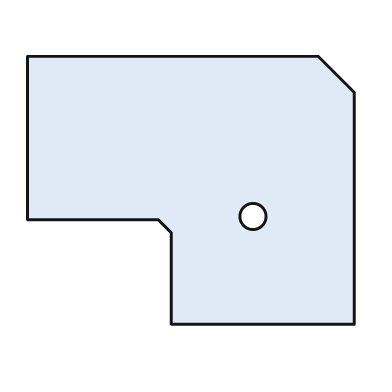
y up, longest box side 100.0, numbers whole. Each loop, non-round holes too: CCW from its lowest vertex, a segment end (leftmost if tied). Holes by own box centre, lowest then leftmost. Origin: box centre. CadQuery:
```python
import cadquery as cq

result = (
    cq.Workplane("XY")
    .moveTo(-6.0, -41.0)
    .lineTo(50.0, -41.0)
    .lineTo(50.0, 30.0)
    .lineTo(39.0, 41.0)
    .lineTo(-50.0, 41.0)
    .lineTo(-50.0, -9.0)
    .lineTo(-10.0, -9.0)
    .lineTo(-6.0, -13.0)
    .close()
    .moveTo(19.0, -8.0)
    .circle(4.0)
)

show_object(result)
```